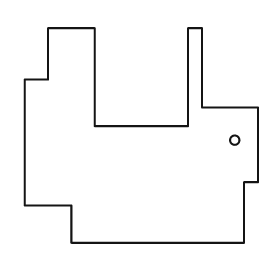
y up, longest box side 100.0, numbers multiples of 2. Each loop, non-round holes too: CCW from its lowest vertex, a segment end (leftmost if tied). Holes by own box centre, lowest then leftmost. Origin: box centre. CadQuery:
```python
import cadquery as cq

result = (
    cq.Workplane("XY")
    .moveTo(-30.0, -46.0)
    .lineTo(44.0, -46.0)
    .lineTo(44.0, -20.0)
    .lineTo(50.0, -20.0)
    .lineTo(50.0, 12.0)
    .lineTo(26.0, 12.0)
    .lineTo(26.0, 46.0)
    .lineTo(20.0, 46.0)
    .lineTo(20.0, 4.0)
    .lineTo(-20.0, 4.0)
    .lineTo(-20.0, 46.0)
    .lineTo(-40.0, 46.0)
    .lineTo(-40.0, 24.0)
    .lineTo(-50.0, 24.0)
    .lineTo(-50.0, -30.0)
    .lineTo(-30.0, -30.0)
    .close()
    .moveTo(40.0, -2.0)
    .circle(2.0)
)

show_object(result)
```